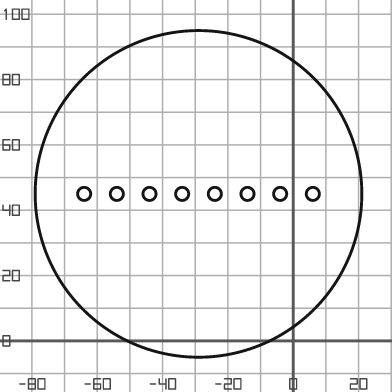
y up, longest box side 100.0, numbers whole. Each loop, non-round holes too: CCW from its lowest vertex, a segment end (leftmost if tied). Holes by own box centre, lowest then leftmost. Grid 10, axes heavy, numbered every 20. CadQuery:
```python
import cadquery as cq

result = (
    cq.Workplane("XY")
    .moveTo(-29.0, 45.0)
    .circle(50.0)
    .moveTo(-64.0, 45.0)
    .circle(2.0)
    .moveTo(-54.0, 45.0)
    .circle(2.0)
    .moveTo(-44.0, 45.0)
    .circle(2.0)
    .moveTo(-34.0, 45.0)
    .circle(2.0)
    .moveTo(-24.0, 45.0)
    .circle(2.0)
    .moveTo(-14.0, 45.0)
    .circle(2.0)
    .moveTo(-4.0, 45.0)
    .circle(2.0)
    .moveTo(6.0, 45.0)
    .circle(2.0)
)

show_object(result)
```